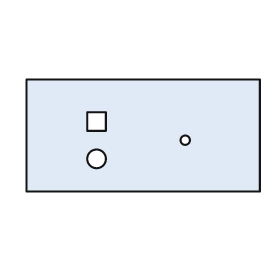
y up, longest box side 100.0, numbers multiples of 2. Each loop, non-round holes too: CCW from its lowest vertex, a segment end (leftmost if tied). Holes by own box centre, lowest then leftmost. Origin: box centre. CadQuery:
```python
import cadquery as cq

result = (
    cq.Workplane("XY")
    .moveTo(-50.0, -24.0)
    .lineTo(50.0, -24.0)
    .lineTo(50.0, 24.0)
    .lineTo(-50.0, 24.0)
    .close()
    .moveTo(-20.0, -10.0)
    .circle(4.0)
    .moveTo(18.0, -2.0)
    .circle(2.0)
    .moveTo(-24.0, 2.0)
    .lineTo(-16.0, 2.0)
    .lineTo(-16.0, 10.0)
    .lineTo(-24.0, 10.0)
    .close()
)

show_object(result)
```